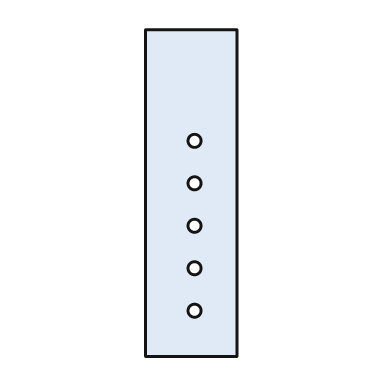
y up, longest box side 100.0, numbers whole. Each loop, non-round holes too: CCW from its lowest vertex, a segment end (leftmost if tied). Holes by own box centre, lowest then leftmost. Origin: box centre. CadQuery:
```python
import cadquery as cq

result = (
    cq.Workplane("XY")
    .moveTo(-14.0, -50.0)
    .lineTo(14.0, -50.0)
    .lineTo(14.0, 50.0)
    .lineTo(-14.0, 50.0)
    .close()
    .moveTo(1.0, -36.0)
    .circle(2.0)
    .moveTo(1.0, -23.0)
    .circle(2.0)
    .moveTo(1.0, -10.0)
    .circle(2.0)
    .moveTo(1.0, 3.0)
    .circle(2.0)
    .moveTo(1.0, 16.0)
    .circle(2.0)
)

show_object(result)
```